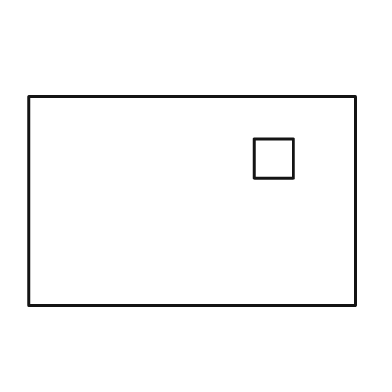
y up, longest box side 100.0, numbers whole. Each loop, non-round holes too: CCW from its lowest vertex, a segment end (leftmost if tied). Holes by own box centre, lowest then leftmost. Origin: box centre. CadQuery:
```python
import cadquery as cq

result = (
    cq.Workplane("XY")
    .moveTo(-50.0, -32.0)
    .lineTo(50.0, -32.0)
    .lineTo(50.0, 32.0)
    .lineTo(-50.0, 32.0)
    .close()
    .moveTo(19.0, 7.0)
    .lineTo(31.0, 7.0)
    .lineTo(31.0, 19.0)
    .lineTo(19.0, 19.0)
    .close()
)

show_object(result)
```